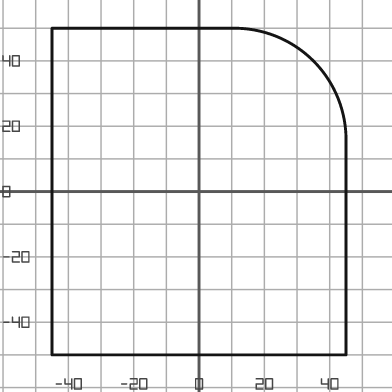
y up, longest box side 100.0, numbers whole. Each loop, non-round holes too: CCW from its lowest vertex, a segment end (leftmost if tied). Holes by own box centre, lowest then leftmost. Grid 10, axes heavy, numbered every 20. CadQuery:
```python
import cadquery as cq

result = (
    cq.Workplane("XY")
    .moveTo(-45.0, -50.0)
    .lineTo(45.0, -50.0)
    .lineTo(45.0, 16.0)
    .threePointArc((35.0, 40.0), (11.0, 50.0))
    .lineTo(-45.0, 50.0)
    .close()
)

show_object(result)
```